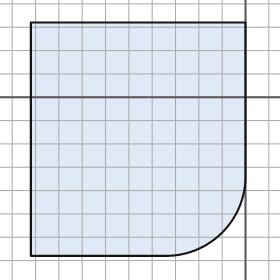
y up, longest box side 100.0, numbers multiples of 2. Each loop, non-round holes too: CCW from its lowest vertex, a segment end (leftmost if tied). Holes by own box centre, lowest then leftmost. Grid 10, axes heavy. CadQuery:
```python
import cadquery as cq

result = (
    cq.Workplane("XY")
    .moveTo(-92.0, -68.0)
    .lineTo(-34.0, -68.0)
    .threePointArc((-10.0, -58.0), (0.0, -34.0))
    .lineTo(0.0, 32.0)
    .lineTo(-92.0, 32.0)
    .close()
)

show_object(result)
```